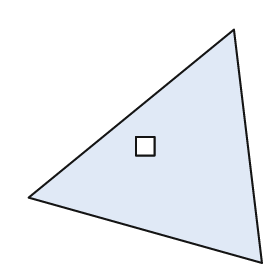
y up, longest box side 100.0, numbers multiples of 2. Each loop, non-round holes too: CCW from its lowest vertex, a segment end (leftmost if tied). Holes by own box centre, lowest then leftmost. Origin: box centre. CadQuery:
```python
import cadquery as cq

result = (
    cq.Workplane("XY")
    .moveTo(50.0, -50.0)
    .lineTo(38.0, 50.0)
    .lineTo(-50.0, -22.0)
    .close()
    .moveTo(-4.0, -4.0)
    .lineTo(4.0, -4.0)
    .lineTo(4.0, 4.0)
    .lineTo(-4.0, 4.0)
    .close()
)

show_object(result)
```